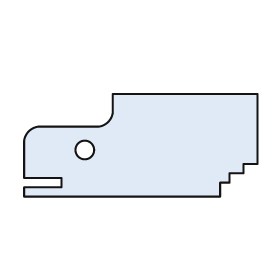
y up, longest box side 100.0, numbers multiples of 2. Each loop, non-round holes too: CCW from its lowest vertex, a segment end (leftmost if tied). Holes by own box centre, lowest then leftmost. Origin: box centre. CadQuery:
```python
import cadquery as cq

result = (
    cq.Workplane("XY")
    .moveTo(-50.0, -22.0)
    .lineTo(34.0, -22.0)
    .lineTo(34.0, -16.0)
    .lineTo(38.0, -16.0)
    .lineTo(38.0, -12.0)
    .lineTo(44.0, -12.0)
    .lineTo(44.0, -8.0)
    .lineTo(50.0, -8.0)
    .lineTo(50.0, 22.0)
    .lineTo(-12.0, 22.0)
    .lineTo(-12.0, 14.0)
    .threePointArc((-14.0, 10.0), (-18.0, 8.0))
    .lineTo(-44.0, 8.0)
    .threePointArc((-48.0, 6.0), (-50.0, 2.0))
    .lineTo(-50.0, -14.0)
    .lineTo(-34.0, -14.0)
    .lineTo(-34.0, -18.0)
    .lineTo(-50.0, -18.0)
    .close()
    .moveTo(-24.0, -2.0)
    .circle(4.0)
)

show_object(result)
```